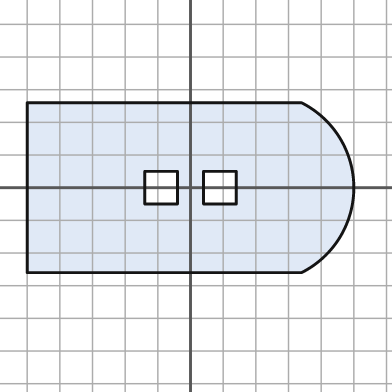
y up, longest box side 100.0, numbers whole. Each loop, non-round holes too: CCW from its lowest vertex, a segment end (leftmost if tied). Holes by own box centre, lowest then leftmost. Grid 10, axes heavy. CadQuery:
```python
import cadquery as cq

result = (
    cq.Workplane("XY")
    .moveTo(-50.0, -26.0)
    .lineTo(34.0, -26.0)
    .threePointArc((50.0, 0.0), (34.0, 26.0))
    .lineTo(-50.0, 26.0)
    .close()
    .moveTo(-14.0, -5.0)
    .lineTo(-4.0, -5.0)
    .lineTo(-4.0, 5.0)
    .lineTo(-14.0, 5.0)
    .close()
    .moveTo(4.0, -5.0)
    .lineTo(14.0, -5.0)
    .lineTo(14.0, 5.0)
    .lineTo(4.0, 5.0)
    .close()
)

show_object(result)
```